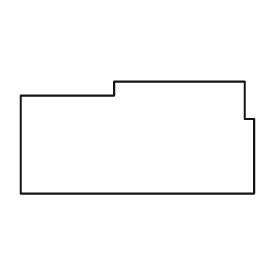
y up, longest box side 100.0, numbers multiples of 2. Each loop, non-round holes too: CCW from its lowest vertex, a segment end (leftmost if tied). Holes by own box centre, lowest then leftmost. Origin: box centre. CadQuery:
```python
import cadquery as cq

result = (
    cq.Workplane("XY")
    .moveTo(-50.0, -24.0)
    .lineTo(50.0, -24.0)
    .lineTo(50.0, 8.0)
    .lineTo(46.0, 8.0)
    .lineTo(46.0, 24.0)
    .lineTo(-10.0, 24.0)
    .lineTo(-10.0, 18.0)
    .lineTo(-50.0, 18.0)
    .close()
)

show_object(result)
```